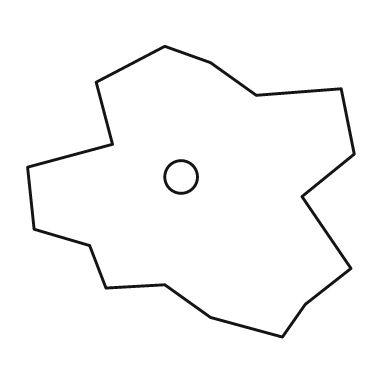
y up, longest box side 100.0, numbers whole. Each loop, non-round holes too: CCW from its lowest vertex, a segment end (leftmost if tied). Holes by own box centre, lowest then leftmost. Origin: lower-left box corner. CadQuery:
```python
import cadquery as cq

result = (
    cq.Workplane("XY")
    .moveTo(78.0, 0.0)
    .lineTo(85.0, 10.0)
    .lineTo(99.0, 21.0)
    .lineTo(84.0, 43.0)
    .lineTo(100.0, 56.0)
    .lineTo(96.0, 76.0)
    .lineTo(70.0, 74.0)
    .lineTo(56.0, 84.0)
    .lineTo(42.0, 89.0)
    .lineTo(21.0, 78.0)
    .lineTo(26.0, 59.0)
    .lineTo(0.0, 52.0)
    .lineTo(2.0, 33.0)
    .lineTo(19.0, 28.0)
    .lineTo(24.0, 15.0)
    .lineTo(42.0, 16.0)
    .lineTo(56.0, 6.0)
    .close()
    .moveTo(47.0, 49.0)
    .circle(5.0)
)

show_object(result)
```